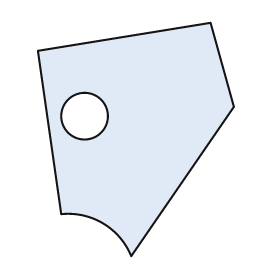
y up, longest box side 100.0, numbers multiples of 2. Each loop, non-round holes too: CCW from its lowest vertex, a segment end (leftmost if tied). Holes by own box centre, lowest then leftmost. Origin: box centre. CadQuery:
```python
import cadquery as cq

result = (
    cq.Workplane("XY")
    .moveTo(-2.0, -50.0)
    .lineTo(42.0, 14.0)
    .lineTo(32.0, 50.0)
    .lineTo(-42.0, 38.0)
    .lineTo(-32.0, -32.0)
    .threePointArc((-14.0, -36.0), (-2.0, -50.0))
    .close()
    .moveTo(-22.0, 10.0)
    .circle(10.0)
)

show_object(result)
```